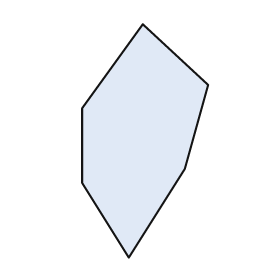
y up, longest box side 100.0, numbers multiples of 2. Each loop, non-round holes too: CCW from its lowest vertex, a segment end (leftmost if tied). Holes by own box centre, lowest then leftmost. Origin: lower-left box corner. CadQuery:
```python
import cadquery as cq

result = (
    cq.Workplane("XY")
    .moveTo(20.0, 0.0)
    .lineTo(44.0, 38.0)
    .lineTo(54.0, 74.0)
    .lineTo(26.0, 100.0)
    .lineTo(0.0, 64.0)
    .lineTo(0.0, 32.0)
    .close()
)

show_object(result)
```